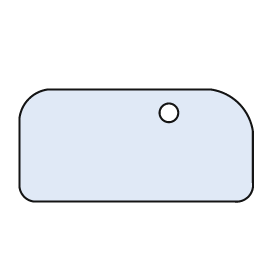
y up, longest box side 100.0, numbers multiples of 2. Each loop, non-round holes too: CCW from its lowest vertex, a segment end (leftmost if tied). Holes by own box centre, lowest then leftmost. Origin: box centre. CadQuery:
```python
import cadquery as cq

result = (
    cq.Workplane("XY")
    .moveTo(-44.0, -24.0)
    .lineTo(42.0, -24.0)
    .threePointArc((48.0, -22.0), (50.0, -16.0))
    .lineTo(50.0, 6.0)
    .threePointArc((44.0, 18.0), (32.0, 24.0))
    .lineTo(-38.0, 24.0)
    .threePointArc((-46.0, 20.0), (-50.0, 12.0))
    .lineTo(-50.0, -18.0)
    .threePointArc((-48.0, -22.0), (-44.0, -24.0))
    .close()
    .moveTo(14.0, 14.0)
    .circle(4.0)
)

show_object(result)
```